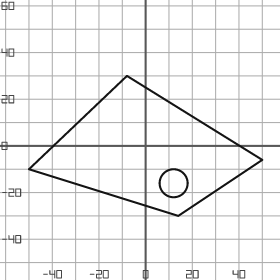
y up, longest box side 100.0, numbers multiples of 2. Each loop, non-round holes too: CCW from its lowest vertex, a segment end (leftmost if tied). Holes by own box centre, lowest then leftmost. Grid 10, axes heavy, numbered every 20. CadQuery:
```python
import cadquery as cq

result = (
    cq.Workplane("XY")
    .moveTo(14.0, -30.0)
    .lineTo(50.0, -6.0)
    .lineTo(-8.0, 30.0)
    .lineTo(-50.0, -10.0)
    .close()
    .moveTo(12.0, -16.0)
    .circle(6.0)
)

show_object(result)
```